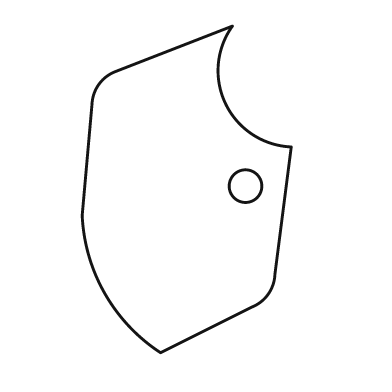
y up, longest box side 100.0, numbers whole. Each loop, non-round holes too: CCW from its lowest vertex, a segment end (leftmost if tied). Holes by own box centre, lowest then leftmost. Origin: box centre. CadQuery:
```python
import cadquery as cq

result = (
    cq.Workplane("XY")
    .moveTo(-8.0, -50.0)
    .lineTo(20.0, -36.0)
    .threePointArc((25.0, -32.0), (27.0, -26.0))
    .lineTo(32.0, 13.0)
    .threePointArc((12.0, 26.0), (14.0, 50.0))
    .lineTo(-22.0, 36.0)
    .threePointArc((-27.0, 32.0), (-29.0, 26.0))
    .lineTo(-32.0, -8.0)
    .threePointArc((-25.0, -32.0), (-8.0, -50.0))
    .close()
    .moveTo(18.0, 1.0)
    .circle(5.0)
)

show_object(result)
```